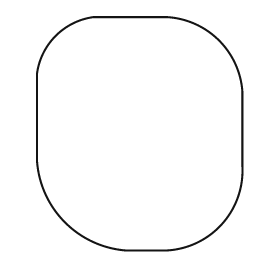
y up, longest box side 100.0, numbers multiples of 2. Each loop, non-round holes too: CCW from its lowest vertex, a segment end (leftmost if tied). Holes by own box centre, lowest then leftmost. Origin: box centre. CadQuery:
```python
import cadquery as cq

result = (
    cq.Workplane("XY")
    .moveTo(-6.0, -50.0)
    .lineTo(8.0, -50.0)
    .threePointArc((34.0, -40.0), (44.0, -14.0))
    .lineTo(44.0, 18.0)
    .threePointArc((34.0, 40.0), (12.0, 50.0))
    .lineTo(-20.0, 50.0)
    .threePointArc((-36.0, 42.0), (-44.0, 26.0))
    .lineTo(-44.0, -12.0)
    .threePointArc((-32.0, -38.0), (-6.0, -50.0))
    .close()
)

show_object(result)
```